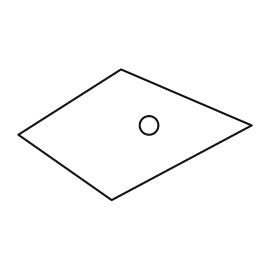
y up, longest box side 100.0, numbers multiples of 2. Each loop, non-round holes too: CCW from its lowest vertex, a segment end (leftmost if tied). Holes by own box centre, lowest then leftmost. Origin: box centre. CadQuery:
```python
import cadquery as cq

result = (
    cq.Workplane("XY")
    .moveTo(-10.0, -28.0)
    .lineTo(50.0, 4.0)
    .lineTo(-6.0, 28.0)
    .lineTo(-50.0, 0.0)
    .close()
    .moveTo(6.0, 4.0)
    .circle(4.0)
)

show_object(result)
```